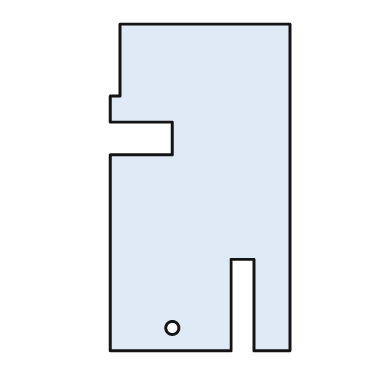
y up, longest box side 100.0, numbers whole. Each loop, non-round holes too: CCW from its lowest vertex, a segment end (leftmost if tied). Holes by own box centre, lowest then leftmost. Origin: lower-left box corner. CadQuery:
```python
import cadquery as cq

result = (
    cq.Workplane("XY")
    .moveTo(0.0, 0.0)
    .lineTo(37.0, 0.0)
    .lineTo(37.0, 28.0)
    .lineTo(44.0, 28.0)
    .lineTo(44.0, 0.0)
    .lineTo(55.0, 0.0)
    .lineTo(55.0, 100.0)
    .lineTo(3.0, 100.0)
    .lineTo(3.0, 78.0)
    .lineTo(0.0, 78.0)
    .lineTo(0.0, 70.0)
    .lineTo(19.0, 70.0)
    .lineTo(19.0, 60.0)
    .lineTo(0.0, 60.0)
    .close()
    .moveTo(19.0, 7.0)
    .circle(2.0)
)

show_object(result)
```